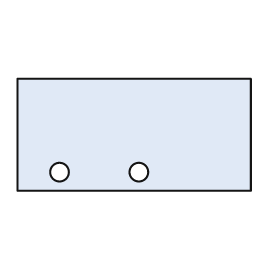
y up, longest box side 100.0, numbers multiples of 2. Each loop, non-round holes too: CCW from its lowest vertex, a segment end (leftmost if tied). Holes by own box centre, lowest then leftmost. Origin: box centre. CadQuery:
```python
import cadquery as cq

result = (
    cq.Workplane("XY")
    .moveTo(-50.0, -24.0)
    .lineTo(50.0, -24.0)
    .lineTo(50.0, 24.0)
    .lineTo(-50.0, 24.0)
    .close()
    .moveTo(-32.0, -16.0)
    .circle(4.0)
    .moveTo(2.0, -16.0)
    .circle(4.0)
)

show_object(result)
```